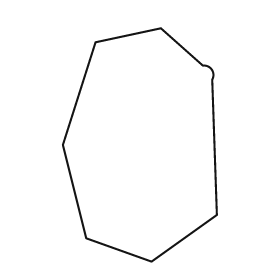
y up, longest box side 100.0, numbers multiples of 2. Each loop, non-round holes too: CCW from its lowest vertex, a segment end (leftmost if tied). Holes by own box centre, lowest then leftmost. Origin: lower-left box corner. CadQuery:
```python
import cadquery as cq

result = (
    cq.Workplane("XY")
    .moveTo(38.0, 0.0)
    .lineTo(66.0, 20.0)
    .lineTo(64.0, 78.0)
    .threePointArc((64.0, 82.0), (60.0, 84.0))
    .lineTo(42.0, 100.0)
    .lineTo(14.0, 94.0)
    .lineTo(0.0, 50.0)
    .lineTo(10.0, 10.0)
    .close()
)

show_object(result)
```